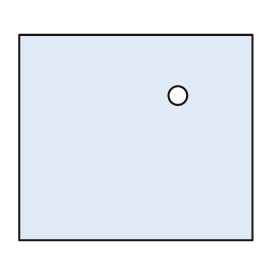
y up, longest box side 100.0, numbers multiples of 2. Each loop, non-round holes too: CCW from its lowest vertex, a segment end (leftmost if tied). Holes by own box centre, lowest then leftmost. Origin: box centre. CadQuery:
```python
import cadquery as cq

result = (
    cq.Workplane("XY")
    .moveTo(-50.0, -44.0)
    .lineTo(50.0, -44.0)
    .lineTo(50.0, 44.0)
    .lineTo(-50.0, 44.0)
    .close()
    .moveTo(18.0, 18.0)
    .circle(4.0)
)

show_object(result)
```